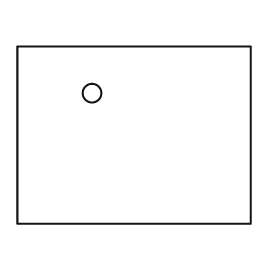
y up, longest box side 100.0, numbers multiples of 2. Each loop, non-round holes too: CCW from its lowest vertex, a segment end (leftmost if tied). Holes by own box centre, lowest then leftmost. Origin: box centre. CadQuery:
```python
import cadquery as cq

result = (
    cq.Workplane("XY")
    .moveTo(-50.0, -38.0)
    .lineTo(50.0, -38.0)
    .lineTo(50.0, 38.0)
    .lineTo(-50.0, 38.0)
    .close()
    .moveTo(-18.0, 18.0)
    .circle(4.0)
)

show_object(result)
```